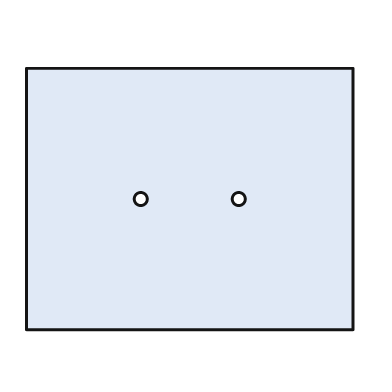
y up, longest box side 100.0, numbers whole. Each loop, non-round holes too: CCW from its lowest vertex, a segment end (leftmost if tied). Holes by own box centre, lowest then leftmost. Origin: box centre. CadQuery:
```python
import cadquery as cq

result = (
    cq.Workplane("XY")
    .moveTo(-50.0, -40.0)
    .lineTo(50.0, -40.0)
    .lineTo(50.0, 40.0)
    .lineTo(-50.0, 40.0)
    .close()
    .moveTo(-15.0, 0.0)
    .circle(2.0)
    .moveTo(15.0, 0.0)
    .circle(2.0)
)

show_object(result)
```